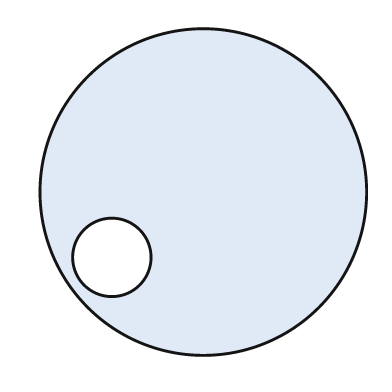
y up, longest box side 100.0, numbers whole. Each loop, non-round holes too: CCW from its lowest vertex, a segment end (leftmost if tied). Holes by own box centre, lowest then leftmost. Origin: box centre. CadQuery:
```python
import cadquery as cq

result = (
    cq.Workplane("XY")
    .moveTo(0.0, 0.0)
    .circle(50.0)
    .moveTo(-28.0, -20.0)
    .circle(12.0)
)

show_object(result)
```